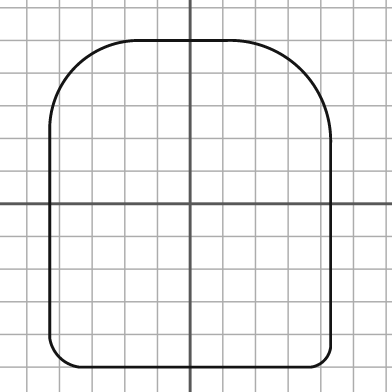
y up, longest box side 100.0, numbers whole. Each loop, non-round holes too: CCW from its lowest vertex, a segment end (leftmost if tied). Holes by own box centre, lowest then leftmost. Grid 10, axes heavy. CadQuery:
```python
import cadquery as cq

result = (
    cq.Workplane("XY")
    .moveTo(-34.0, -50.0)
    .lineTo(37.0, -50.0)
    .threePointArc((41.0, -48.0), (43.0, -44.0))
    .lineTo(43.0, 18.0)
    .threePointArc((34.0, 41.0), (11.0, 50.0))
    .lineTo(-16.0, 50.0)
    .threePointArc((-35.0, 42.0), (-43.0, 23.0))
    .lineTo(-43.0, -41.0)
    .threePointArc((-40.0, -47.0), (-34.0, -50.0))
    .close()
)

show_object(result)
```